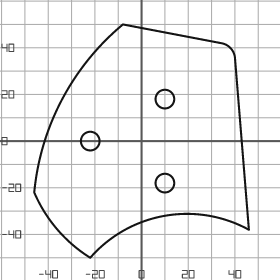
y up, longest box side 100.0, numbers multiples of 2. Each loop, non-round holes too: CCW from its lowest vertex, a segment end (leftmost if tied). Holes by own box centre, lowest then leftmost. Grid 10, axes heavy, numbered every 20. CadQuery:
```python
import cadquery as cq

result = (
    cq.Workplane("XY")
    .moveTo(-22.0, -50.0)
    .threePointArc((10.0, -32.0), (46.0, -38.0))
    .lineTo(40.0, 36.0)
    .threePointArc((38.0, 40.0), (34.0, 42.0))
    .lineTo(-8.0, 50.0)
    .threePointArc((-34.0, 18.0), (-46.0, -22.0))
    .threePointArc((-36.0, -38.0), (-22.0, -50.0))
    .close()
    .moveTo(10.0, -18.0)
    .circle(4.0)
    .moveTo(-22.0, 0.0)
    .circle(4.0)
    .moveTo(10.0, 18.0)
    .circle(4.0)
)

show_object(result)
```